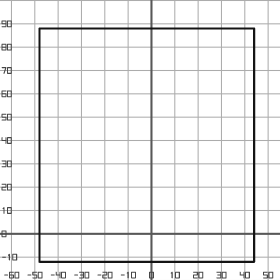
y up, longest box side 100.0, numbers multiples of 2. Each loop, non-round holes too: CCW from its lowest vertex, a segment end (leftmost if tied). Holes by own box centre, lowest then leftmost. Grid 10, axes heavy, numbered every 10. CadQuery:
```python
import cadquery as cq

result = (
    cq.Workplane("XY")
    .moveTo(-48.0, -12.0)
    .lineTo(44.0, -12.0)
    .lineTo(44.0, 88.0)
    .lineTo(-48.0, 88.0)
    .close()
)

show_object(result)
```